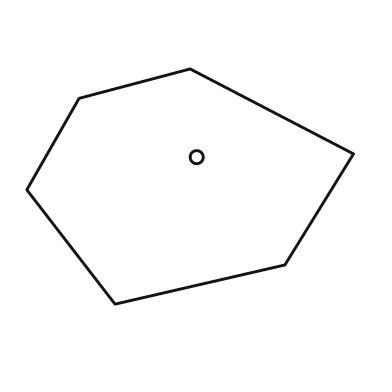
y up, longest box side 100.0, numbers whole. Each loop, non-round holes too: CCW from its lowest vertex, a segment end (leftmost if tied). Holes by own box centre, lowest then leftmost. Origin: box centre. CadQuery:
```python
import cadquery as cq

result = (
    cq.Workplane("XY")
    .moveTo(-23.0, -36.0)
    .lineTo(29.0, -24.0)
    .lineTo(50.0, 10.0)
    .lineTo(0.0, 36.0)
    .lineTo(-34.0, 27.0)
    .lineTo(-50.0, -1.0)
    .close()
    .moveTo(2.0, 9.0)
    .circle(2.0)
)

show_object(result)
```